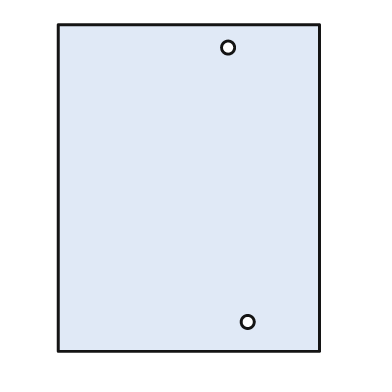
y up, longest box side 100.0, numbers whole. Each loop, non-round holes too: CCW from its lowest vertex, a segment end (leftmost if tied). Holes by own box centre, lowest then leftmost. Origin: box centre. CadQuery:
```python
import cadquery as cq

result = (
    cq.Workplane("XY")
    .moveTo(-40.0, -50.0)
    .lineTo(40.0, -50.0)
    .lineTo(40.0, 50.0)
    .lineTo(-40.0, 50.0)
    .close()
    .moveTo(18.0, -41.0)
    .circle(2.0)
    .moveTo(12.0, 43.0)
    .circle(2.0)
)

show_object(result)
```